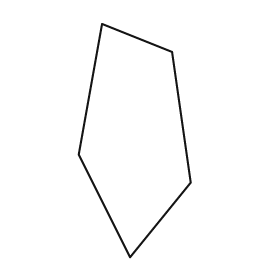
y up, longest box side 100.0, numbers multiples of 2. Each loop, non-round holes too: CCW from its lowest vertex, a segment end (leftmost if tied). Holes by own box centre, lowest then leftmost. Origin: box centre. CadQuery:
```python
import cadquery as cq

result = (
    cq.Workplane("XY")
    .moveTo(-2.0, -50.0)
    .lineTo(24.0, -18.0)
    .lineTo(16.0, 38.0)
    .lineTo(-14.0, 50.0)
    .lineTo(-24.0, -6.0)
    .close()
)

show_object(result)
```